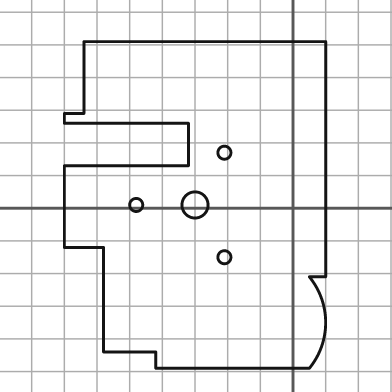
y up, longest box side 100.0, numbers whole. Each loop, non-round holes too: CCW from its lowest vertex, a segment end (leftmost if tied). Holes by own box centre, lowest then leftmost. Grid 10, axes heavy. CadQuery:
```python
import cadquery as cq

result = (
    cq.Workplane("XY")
    .moveTo(-42.0, -49.0)
    .lineTo(5.0, -49.0)
    .threePointArc((10.0, -35.0), (5.0, -21.0))
    .lineTo(10.0, -21.0)
    .lineTo(10.0, 51.0)
    .lineTo(-64.0, 51.0)
    .lineTo(-64.0, 29.0)
    .lineTo(-70.0, 29.0)
    .lineTo(-70.0, 26.0)
    .lineTo(-32.0, 26.0)
    .lineTo(-32.0, 13.0)
    .lineTo(-70.0, 13.0)
    .lineTo(-70.0, -12.0)
    .lineTo(-58.0, -12.0)
    .lineTo(-58.0, -44.0)
    .lineTo(-42.0, -44.0)
    .close()
    .moveTo(-21.0, -15.0)
    .circle(2.0)
    .moveTo(-48.0, 1.0)
    .circle(2.0)
    .moveTo(-30.0, 1.0)
    .circle(4.0)
    .moveTo(-21.0, 17.0)
    .circle(2.0)
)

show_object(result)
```